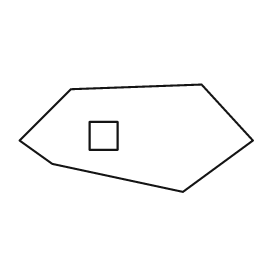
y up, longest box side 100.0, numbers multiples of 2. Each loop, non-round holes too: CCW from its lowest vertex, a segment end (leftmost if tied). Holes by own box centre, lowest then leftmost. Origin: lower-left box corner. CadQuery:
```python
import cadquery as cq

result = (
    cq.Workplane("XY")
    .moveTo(70.0, 0.0)
    .lineTo(100.0, 22.0)
    .lineTo(78.0, 46.0)
    .lineTo(22.0, 44.0)
    .lineTo(0.0, 22.0)
    .lineTo(14.0, 12.0)
    .close()
    .moveTo(30.0, 18.0)
    .lineTo(42.0, 18.0)
    .lineTo(42.0, 30.0)
    .lineTo(30.0, 30.0)
    .close()
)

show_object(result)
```